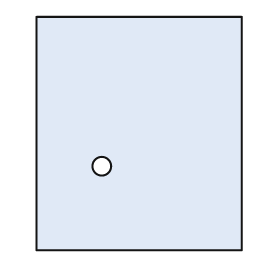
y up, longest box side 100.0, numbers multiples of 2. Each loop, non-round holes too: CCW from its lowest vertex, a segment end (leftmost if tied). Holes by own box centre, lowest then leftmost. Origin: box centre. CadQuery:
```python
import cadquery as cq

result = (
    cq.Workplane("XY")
    .moveTo(-44.0, -50.0)
    .lineTo(44.0, -50.0)
    .lineTo(44.0, 50.0)
    .lineTo(-44.0, 50.0)
    .close()
    .moveTo(-16.0, -14.0)
    .circle(4.0)
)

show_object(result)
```